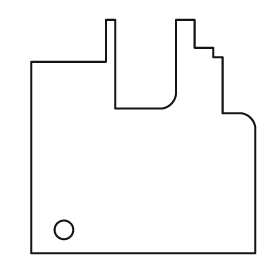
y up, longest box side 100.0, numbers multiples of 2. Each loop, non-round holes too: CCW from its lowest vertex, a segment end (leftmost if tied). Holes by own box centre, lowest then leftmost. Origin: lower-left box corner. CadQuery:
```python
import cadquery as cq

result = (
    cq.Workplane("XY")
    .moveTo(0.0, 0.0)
    .lineTo(96.0, 0.0)
    .lineTo(96.0, 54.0)
    .threePointArc((94.0, 58.0), (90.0, 60.0))
    .lineTo(82.0, 60.0)
    .lineTo(82.0, 84.0)
    .lineTo(78.0, 84.0)
    .lineTo(78.0, 88.0)
    .lineTo(70.0, 88.0)
    .lineTo(70.0, 100.0)
    .lineTo(62.0, 100.0)
    .lineTo(62.0, 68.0)
    .threePointArc((60.0, 64.0), (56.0, 62.0))
    .lineTo(36.0, 62.0)
    .lineTo(36.0, 100.0)
    .lineTo(32.0, 100.0)
    .lineTo(32.0, 82.0)
    .lineTo(0.0, 82.0)
    .close()
    .moveTo(14.0, 10.0)
    .circle(4.0)
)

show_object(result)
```